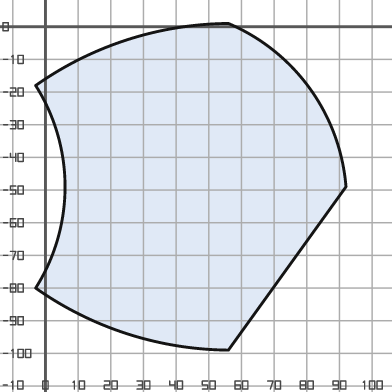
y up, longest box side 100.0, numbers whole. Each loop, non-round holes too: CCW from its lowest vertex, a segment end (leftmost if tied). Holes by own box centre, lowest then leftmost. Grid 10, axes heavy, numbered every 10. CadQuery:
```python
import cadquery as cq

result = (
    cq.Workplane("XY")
    .moveTo(56.0, -99.0)
    .lineTo(92.0, -49.0)
    .threePointArc((81.0, -19.0), (56.0, 1.0))
    .threePointArc((25.0, -4.0), (-3.0, -18.0))
    .threePointArc((6.0, -49.0), (-3.0, -80.0))
    .threePointArc((25.0, -94.0), (56.0, -99.0))
    .close()
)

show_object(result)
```